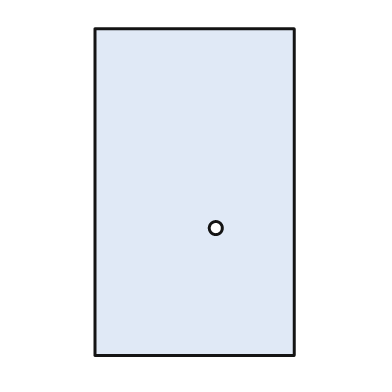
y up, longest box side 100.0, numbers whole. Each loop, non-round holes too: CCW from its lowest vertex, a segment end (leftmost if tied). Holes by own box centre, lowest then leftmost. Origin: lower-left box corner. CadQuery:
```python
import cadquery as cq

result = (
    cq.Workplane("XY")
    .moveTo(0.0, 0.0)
    .lineTo(61.0, 0.0)
    .lineTo(61.0, 100.0)
    .lineTo(0.0, 100.0)
    .close()
    .moveTo(37.0, 39.0)
    .circle(2.0)
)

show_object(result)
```